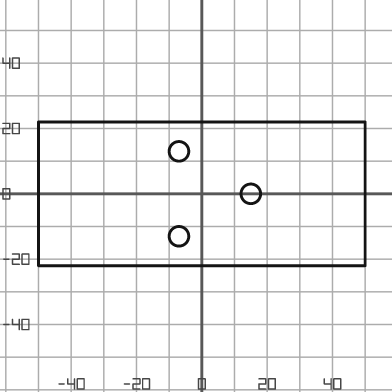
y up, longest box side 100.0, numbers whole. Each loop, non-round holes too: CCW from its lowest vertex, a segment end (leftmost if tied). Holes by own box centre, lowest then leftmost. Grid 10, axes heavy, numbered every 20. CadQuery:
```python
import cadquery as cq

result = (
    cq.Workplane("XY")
    .moveTo(-50.0, -22.0)
    .lineTo(50.0, -22.0)
    .lineTo(50.0, 22.0)
    .lineTo(-50.0, 22.0)
    .close()
    .moveTo(-7.0, -13.0)
    .circle(3.0)
    .moveTo(15.0, 0.0)
    .circle(3.0)
    .moveTo(-7.0, 13.0)
    .circle(3.0)
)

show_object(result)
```